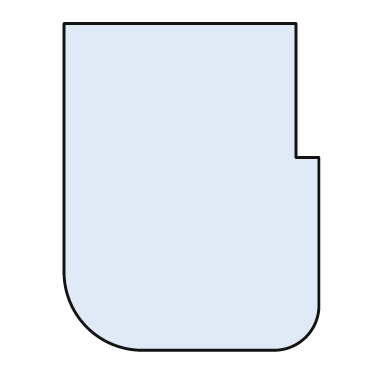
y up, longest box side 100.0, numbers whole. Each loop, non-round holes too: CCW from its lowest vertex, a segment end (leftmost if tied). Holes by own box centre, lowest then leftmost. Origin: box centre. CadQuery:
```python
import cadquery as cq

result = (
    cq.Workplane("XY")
    .moveTo(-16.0, -50.0)
    .lineTo(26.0, -50.0)
    .threePointArc((35.0, -46.0), (39.0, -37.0))
    .lineTo(39.0, 9.0)
    .lineTo(32.0, 9.0)
    .lineTo(32.0, 50.0)
    .lineTo(-39.0, 50.0)
    .lineTo(-39.0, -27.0)
    .threePointArc((-32.0, -43.0), (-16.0, -50.0))
    .close()
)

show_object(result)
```